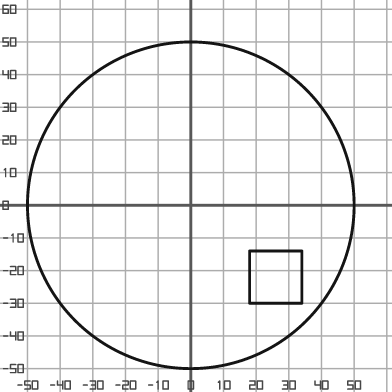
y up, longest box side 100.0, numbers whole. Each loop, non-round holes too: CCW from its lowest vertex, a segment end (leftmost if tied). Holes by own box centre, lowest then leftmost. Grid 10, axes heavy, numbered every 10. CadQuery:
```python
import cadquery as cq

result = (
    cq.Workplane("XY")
    .moveTo(0.0, 0.0)
    .circle(50.0)
    .moveTo(18.0, -30.0)
    .lineTo(34.0, -30.0)
    .lineTo(34.0, -14.0)
    .lineTo(18.0, -14.0)
    .close()
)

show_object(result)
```